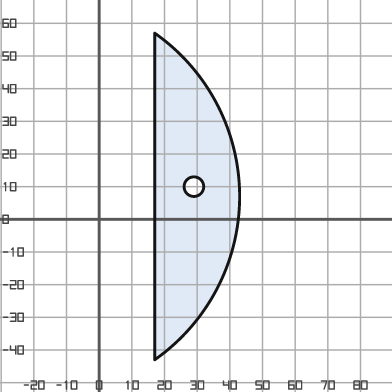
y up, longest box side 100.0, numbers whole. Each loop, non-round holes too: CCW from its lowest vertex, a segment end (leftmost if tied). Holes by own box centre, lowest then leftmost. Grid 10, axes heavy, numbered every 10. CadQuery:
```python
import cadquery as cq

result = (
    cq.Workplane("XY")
    .moveTo(17.0, -43.0)
    .threePointArc((43.0, 7.0), (17.0, 57.0))
    .close()
    .moveTo(29.0, 10.0)
    .circle(3.0)
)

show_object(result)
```